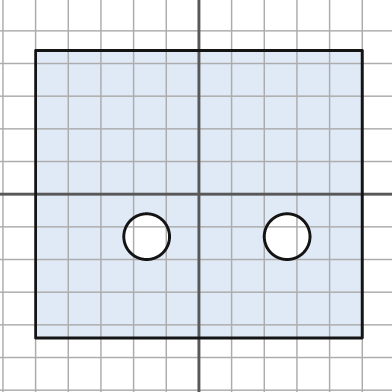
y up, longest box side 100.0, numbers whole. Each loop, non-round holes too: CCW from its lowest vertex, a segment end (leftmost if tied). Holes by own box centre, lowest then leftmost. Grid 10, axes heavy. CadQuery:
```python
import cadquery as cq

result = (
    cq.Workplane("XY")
    .moveTo(-50.0, -44.0)
    .lineTo(50.0, -44.0)
    .lineTo(50.0, 44.0)
    .lineTo(-50.0, 44.0)
    .close()
    .moveTo(-16.0, -13.0)
    .circle(7.0)
    .moveTo(27.0, -13.0)
    .circle(7.0)
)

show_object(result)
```